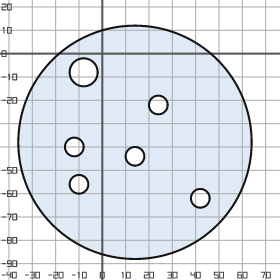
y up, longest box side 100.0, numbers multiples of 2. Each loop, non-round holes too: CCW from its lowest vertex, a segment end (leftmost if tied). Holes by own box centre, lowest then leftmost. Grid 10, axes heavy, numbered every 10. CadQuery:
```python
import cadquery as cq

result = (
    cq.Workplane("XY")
    .moveTo(14.0, -38.0)
    .circle(50.0)
    .moveTo(42.0, -62.0)
    .circle(4.0)
    .moveTo(-10.0, -56.0)
    .circle(4.0)
    .moveTo(14.0, -44.0)
    .circle(4.0)
    .moveTo(-12.0, -40.0)
    .circle(4.0)
    .moveTo(24.0, -22.0)
    .circle(4.0)
    .moveTo(-8.0, -8.0)
    .circle(6.0)
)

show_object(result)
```